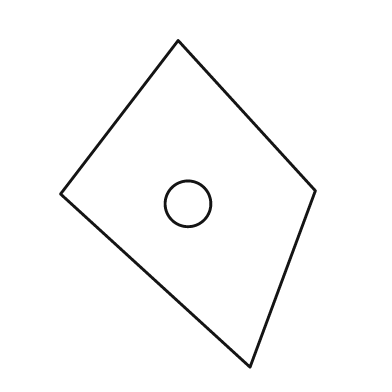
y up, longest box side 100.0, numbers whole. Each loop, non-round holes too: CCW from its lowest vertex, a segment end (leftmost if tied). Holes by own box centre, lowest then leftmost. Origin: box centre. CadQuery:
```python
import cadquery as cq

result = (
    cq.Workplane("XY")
    .moveTo(19.0, -50.0)
    .lineTo(39.0, 4.0)
    .lineTo(-3.0, 50.0)
    .lineTo(-39.0, 3.0)
    .close()
    .moveTo(0.0, 0.0)
    .circle(7.0)
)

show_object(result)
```